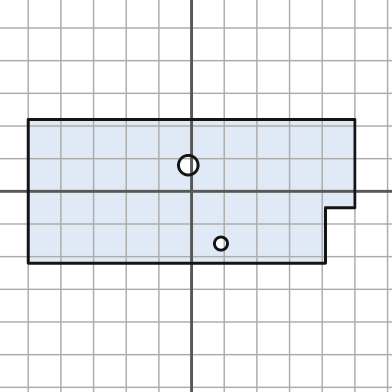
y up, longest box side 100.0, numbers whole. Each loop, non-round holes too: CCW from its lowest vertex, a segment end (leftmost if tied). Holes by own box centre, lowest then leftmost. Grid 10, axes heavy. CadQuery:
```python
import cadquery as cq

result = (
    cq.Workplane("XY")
    .moveTo(-50.0, -22.0)
    .lineTo(41.0, -22.0)
    .lineTo(41.0, -5.0)
    .lineTo(50.0, -5.0)
    .lineTo(50.0, 22.0)
    .lineTo(-50.0, 22.0)
    .close()
    .moveTo(9.0, -16.0)
    .circle(2.0)
    .moveTo(-1.0, 8.0)
    .circle(3.0)
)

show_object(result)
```